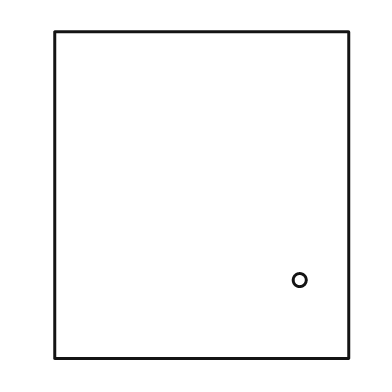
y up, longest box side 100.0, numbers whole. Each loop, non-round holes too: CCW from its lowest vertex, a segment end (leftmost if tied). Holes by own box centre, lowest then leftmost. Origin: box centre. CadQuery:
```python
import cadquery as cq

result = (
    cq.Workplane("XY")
    .moveTo(-45.0, -50.0)
    .lineTo(45.0, -50.0)
    .lineTo(45.0, 50.0)
    .lineTo(-45.0, 50.0)
    .close()
    .moveTo(30.0, -26.0)
    .circle(2.0)
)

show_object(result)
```